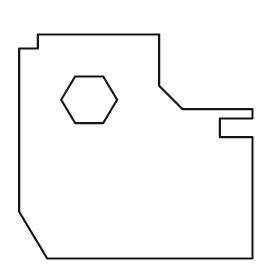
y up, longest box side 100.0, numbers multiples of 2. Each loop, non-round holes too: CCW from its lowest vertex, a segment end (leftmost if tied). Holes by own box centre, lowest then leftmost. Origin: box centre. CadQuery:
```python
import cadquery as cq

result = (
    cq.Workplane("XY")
    .moveTo(-38.0, -48.0)
    .lineTo(50.0, -48.0)
    .lineTo(50.0, 4.0)
    .lineTo(36.0, 4.0)
    .lineTo(36.0, 12.0)
    .lineTo(50.0, 12.0)
    .lineTo(50.0, 16.0)
    .lineTo(20.0, 16.0)
    .lineTo(10.0, 26.0)
    .lineTo(10.0, 48.0)
    .lineTo(-42.0, 48.0)
    .lineTo(-42.0, 42.0)
    .lineTo(-50.0, 42.0)
    .lineTo(-50.0, -28.0)
    .close()
    .moveTo(-26.0, 10.0)
    .lineTo(-14.0, 10.0)
    .lineTo(-8.0, 20.0)
    .lineTo(-14.0, 30.0)
    .lineTo(-26.0, 30.0)
    .lineTo(-32.0, 20.0)
    .close()
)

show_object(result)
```